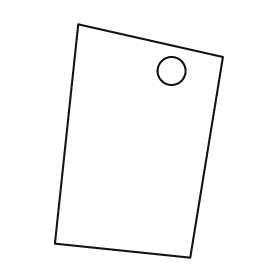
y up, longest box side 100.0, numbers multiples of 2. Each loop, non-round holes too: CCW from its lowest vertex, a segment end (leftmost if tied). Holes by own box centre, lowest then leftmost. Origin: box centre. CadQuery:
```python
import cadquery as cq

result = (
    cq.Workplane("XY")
    .moveTo(22.0, -50.0)
    .lineTo(36.0, 36.0)
    .lineTo(-26.0, 50.0)
    .lineTo(-36.0, -44.0)
    .close()
    .moveTo(14.0, 30.0)
    .circle(6.0)
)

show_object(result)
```